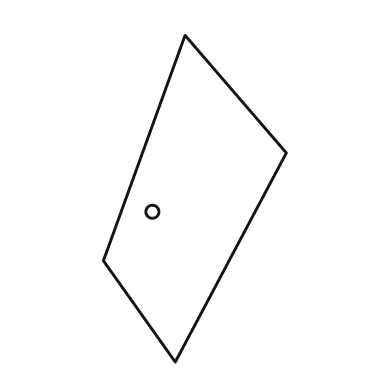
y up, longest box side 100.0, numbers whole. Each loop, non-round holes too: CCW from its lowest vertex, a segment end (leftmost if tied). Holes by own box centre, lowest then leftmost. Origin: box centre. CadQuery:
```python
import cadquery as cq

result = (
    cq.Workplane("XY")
    .moveTo(-6.0, -50.0)
    .lineTo(28.0, 14.0)
    .lineTo(-3.0, 50.0)
    .lineTo(-28.0, -19.0)
    .close()
    .moveTo(-13.0, -4.0)
    .circle(2.0)
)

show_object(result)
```